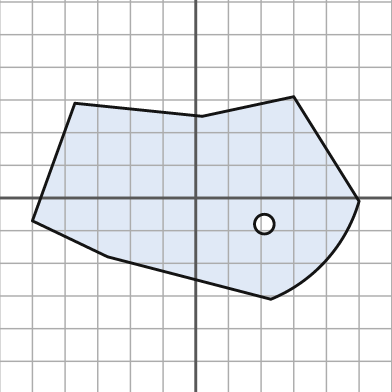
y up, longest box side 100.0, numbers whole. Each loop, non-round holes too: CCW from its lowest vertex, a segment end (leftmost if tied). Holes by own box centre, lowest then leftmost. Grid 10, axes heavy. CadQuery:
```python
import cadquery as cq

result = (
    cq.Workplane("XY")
    .moveTo(23.0, -31.0)
    .threePointArc((40.0, -19.0), (50.0, -1.0))
    .lineTo(30.0, 31.0)
    .lineTo(2.0, 25.0)
    .lineTo(-37.0, 29.0)
    .lineTo(-50.0, -7.0)
    .lineTo(-27.0, -18.0)
    .close()
    .moveTo(21.0, -8.0)
    .circle(3.0)
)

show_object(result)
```